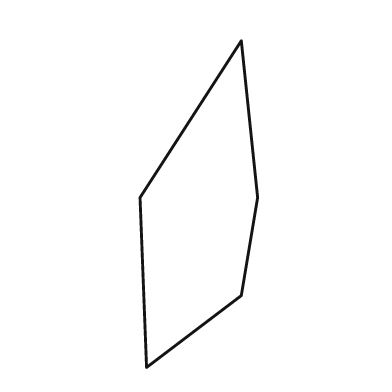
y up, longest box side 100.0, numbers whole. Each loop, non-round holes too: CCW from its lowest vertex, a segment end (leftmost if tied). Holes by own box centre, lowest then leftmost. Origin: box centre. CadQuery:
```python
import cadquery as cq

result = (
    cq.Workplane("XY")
    .moveTo(-16.0, -50.0)
    .lineTo(13.0, -28.0)
    .lineTo(18.0, 2.0)
    .lineTo(13.0, 50.0)
    .lineTo(-18.0, 2.0)
    .close()
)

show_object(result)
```